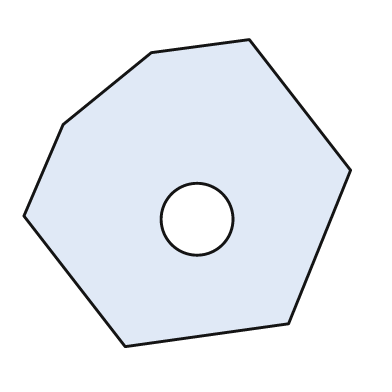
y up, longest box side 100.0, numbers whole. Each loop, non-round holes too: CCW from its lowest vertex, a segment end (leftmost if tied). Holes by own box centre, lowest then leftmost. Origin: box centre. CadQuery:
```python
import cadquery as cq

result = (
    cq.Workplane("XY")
    .moveTo(-19.0, -47.0)
    .lineTo(31.0, -40.0)
    .lineTo(50.0, 7.0)
    .lineTo(19.0, 47.0)
    .lineTo(-11.0, 43.0)
    .lineTo(-38.0, 21.0)
    .lineTo(-50.0, -7.0)
    .close()
    .moveTo(3.0, -8.0)
    .circle(11.0)
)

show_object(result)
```